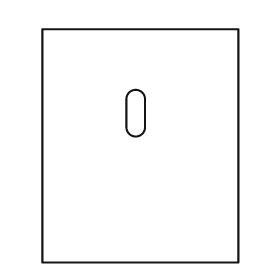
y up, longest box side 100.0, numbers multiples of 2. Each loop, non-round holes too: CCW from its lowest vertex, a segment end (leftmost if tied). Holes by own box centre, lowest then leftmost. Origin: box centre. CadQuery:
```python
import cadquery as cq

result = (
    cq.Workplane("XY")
    .moveTo(-42.0, -50.0)
    .lineTo(42.0, -50.0)
    .lineTo(42.0, 50.0)
    .lineTo(-42.0, 50.0)
    .close()
    .moveTo(-6.0, 8.0)
    .threePointArc((-2.0, 4.0), (2.0, 8.0))
    .lineTo(2.0, 20.0)
    .threePointArc((-2.0, 24.0), (-6.0, 20.0))
    .close()
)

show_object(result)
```